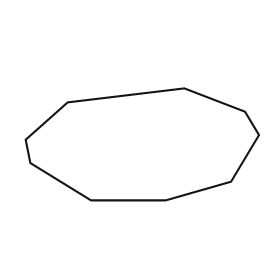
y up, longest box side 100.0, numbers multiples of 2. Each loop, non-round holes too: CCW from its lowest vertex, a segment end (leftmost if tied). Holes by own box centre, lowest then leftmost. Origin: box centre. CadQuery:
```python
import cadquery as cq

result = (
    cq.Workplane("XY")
    .moveTo(-22.0, -24.0)
    .lineTo(10.0, -24.0)
    .lineTo(38.0, -16.0)
    .lineTo(50.0, 4.0)
    .lineTo(44.0, 14.0)
    .lineTo(18.0, 24.0)
    .lineTo(-32.0, 18.0)
    .lineTo(-50.0, 2.0)
    .lineTo(-48.0, -8.0)
    .close()
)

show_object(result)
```